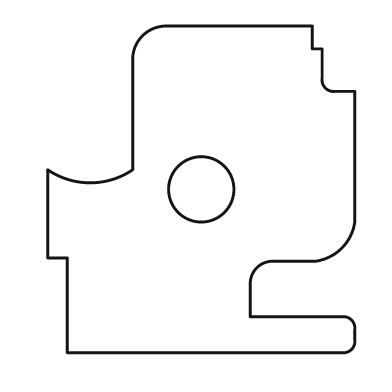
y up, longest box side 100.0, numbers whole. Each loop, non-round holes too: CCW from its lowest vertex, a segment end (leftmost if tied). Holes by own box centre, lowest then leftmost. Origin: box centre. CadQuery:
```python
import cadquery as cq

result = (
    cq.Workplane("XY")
    .moveTo(-41.0, -50.0)
    .lineTo(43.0, -50.0)
    .threePointArc((46.0, -49.0), (47.0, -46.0))
    .lineTo(47.0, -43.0)
    .threePointArc((46.0, -40.0), (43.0, -39.0))
    .lineTo(15.0, -39.0)
    .lineTo(15.0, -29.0)
    .threePointArc((17.0, -24.0), (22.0, -22.0))
    .lineTo(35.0, -22.0)
    .threePointArc((43.0, -18.0), (47.0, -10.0))
    .lineTo(47.0, 30.0)
    .lineTo(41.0, 30.0)
    .threePointArc((38.0, 31.0), (37.0, 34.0))
    .lineTo(37.0, 43.0)
    .lineTo(34.0, 43.0)
    .lineTo(34.0, 50.0)
    .lineTo(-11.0, 50.0)
    .threePointArc((-18.0, 47.0), (-21.0, 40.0))
    .lineTo(-21.0, 6.0)
    .threePointArc((-34.0, 2.0), (-47.0, 6.0))
    .lineTo(-47.0, -21.0)
    .lineTo(-41.0, -21.0)
    .close()
    .moveTo(0.0, 0.0)
    .circle(10.0)
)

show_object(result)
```